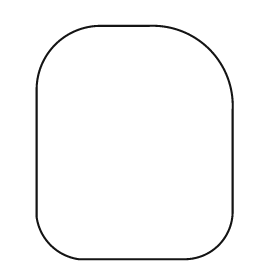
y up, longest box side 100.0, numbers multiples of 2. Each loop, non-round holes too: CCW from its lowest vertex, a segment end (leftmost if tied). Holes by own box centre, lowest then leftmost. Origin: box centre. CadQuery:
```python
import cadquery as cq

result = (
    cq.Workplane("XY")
    .moveTo(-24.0, -50.0)
    .lineTo(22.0, -50.0)
    .threePointArc((36.0, -44.0), (42.0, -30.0))
    .lineTo(42.0, 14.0)
    .threePointArc((32.0, 40.0), (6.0, 50.0))
    .lineTo(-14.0, 50.0)
    .threePointArc((-34.0, 42.0), (-42.0, 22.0))
    .lineTo(-42.0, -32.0)
    .threePointArc((-36.0, -44.0), (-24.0, -50.0))
    .close()
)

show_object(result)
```